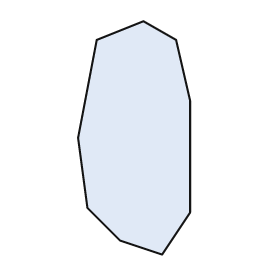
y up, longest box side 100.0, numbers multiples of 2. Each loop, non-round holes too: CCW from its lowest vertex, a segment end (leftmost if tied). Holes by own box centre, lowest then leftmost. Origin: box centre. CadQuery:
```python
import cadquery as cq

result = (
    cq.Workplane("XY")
    .moveTo(12.0, -50.0)
    .lineTo(24.0, -32.0)
    .lineTo(24.0, 16.0)
    .lineTo(18.0, 42.0)
    .lineTo(4.0, 50.0)
    .lineTo(-16.0, 42.0)
    .lineTo(-24.0, 0.0)
    .lineTo(-20.0, -30.0)
    .lineTo(-6.0, -44.0)
    .close()
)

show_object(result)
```